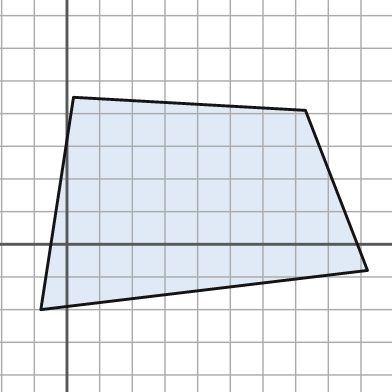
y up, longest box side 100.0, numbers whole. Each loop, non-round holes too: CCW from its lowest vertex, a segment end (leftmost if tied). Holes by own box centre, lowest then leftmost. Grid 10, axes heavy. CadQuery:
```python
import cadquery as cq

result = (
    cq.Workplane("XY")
    .moveTo(-8.0, -20.0)
    .lineTo(92.0, -8.0)
    .lineTo(73.0, 41.0)
    .lineTo(2.0, 45.0)
    .close()
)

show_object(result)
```